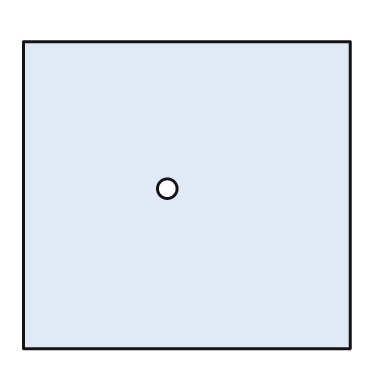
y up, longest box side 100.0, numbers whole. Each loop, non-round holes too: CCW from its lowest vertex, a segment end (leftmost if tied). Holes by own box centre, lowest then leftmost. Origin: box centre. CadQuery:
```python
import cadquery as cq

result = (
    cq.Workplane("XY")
    .moveTo(-50.0, -47.0)
    .lineTo(50.0, -47.0)
    .lineTo(50.0, 47.0)
    .lineTo(-50.0, 47.0)
    .close()
    .moveTo(-6.0, 2.0)
    .circle(3.0)
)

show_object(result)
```